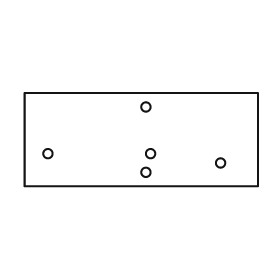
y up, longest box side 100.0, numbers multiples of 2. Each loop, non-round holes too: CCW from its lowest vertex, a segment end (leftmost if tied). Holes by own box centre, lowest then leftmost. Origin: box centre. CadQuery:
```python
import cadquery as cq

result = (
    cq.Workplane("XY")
    .moveTo(-50.0, -20.0)
    .lineTo(50.0, -20.0)
    .lineTo(50.0, 20.0)
    .lineTo(-50.0, 20.0)
    .close()
    .moveTo(2.0, -14.0)
    .circle(2.0)
    .moveTo(34.0, -10.0)
    .circle(2.0)
    .moveTo(-40.0, -6.0)
    .circle(2.0)
    .moveTo(4.0, -6.0)
    .circle(2.0)
    .moveTo(2.0, 14.0)
    .circle(2.0)
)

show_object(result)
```